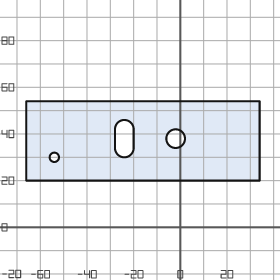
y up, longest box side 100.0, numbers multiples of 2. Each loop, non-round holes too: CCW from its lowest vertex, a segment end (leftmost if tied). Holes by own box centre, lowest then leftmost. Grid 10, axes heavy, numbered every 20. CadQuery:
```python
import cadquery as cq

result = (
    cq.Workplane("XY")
    .moveTo(-66.0, 20.0)
    .lineTo(34.0, 20.0)
    .lineTo(34.0, 54.0)
    .lineTo(-66.0, 54.0)
    .close()
    .moveTo(-54.0, 30.0)
    .circle(2.0)
    .moveTo(-28.0, 34.0)
    .threePointArc((-24.0, 30.0), (-20.0, 34.0))
    .lineTo(-20.0, 42.0)
    .threePointArc((-24.0, 46.0), (-28.0, 42.0))
    .close()
    .moveTo(-2.0, 38.0)
    .circle(4.0)
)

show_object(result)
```